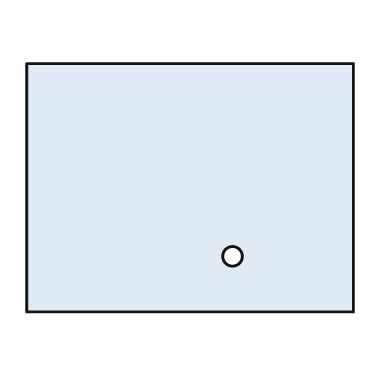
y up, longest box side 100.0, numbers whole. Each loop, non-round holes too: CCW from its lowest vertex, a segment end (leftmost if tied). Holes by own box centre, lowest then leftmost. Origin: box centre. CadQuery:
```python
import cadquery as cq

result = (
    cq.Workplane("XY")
    .moveTo(-50.0, -38.0)
    .lineTo(50.0, -38.0)
    .lineTo(50.0, 38.0)
    .lineTo(-50.0, 38.0)
    .close()
    .moveTo(13.0, -21.0)
    .circle(3.0)
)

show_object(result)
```